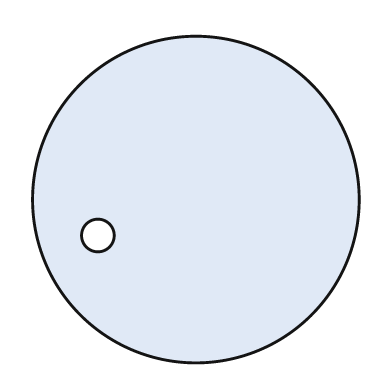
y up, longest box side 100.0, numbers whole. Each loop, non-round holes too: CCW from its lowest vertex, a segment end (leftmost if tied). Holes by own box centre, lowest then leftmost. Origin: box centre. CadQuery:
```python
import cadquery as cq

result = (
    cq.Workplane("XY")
    .moveTo(0.0, 0.0)
    .circle(50.0)
    .moveTo(-30.0, -11.0)
    .circle(5.0)
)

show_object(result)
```